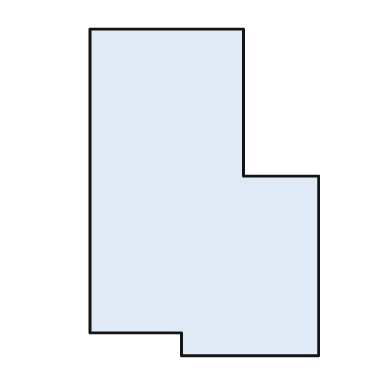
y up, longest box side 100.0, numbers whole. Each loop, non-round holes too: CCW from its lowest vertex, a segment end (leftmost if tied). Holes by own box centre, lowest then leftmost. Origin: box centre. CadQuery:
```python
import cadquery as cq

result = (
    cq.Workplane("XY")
    .moveTo(-7.0, -50.0)
    .lineTo(35.0, -50.0)
    .lineTo(35.0, 5.0)
    .lineTo(12.0, 5.0)
    .lineTo(12.0, 50.0)
    .lineTo(-35.0, 50.0)
    .lineTo(-35.0, -43.0)
    .lineTo(-7.0, -43.0)
    .close()
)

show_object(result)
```